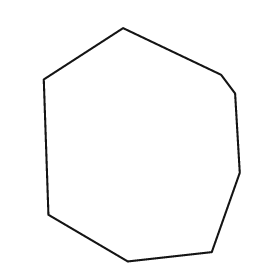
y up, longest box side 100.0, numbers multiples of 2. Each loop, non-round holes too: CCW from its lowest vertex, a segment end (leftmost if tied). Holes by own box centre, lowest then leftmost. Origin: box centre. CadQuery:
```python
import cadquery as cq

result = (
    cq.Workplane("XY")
    .moveTo(-6.0, -50.0)
    .lineTo(30.0, -46.0)
    .lineTo(42.0, -12.0)
    .lineTo(40.0, 22.0)
    .lineTo(34.0, 30.0)
    .lineTo(-8.0, 50.0)
    .lineTo(-42.0, 28.0)
    .lineTo(-40.0, -30.0)
    .close()
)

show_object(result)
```